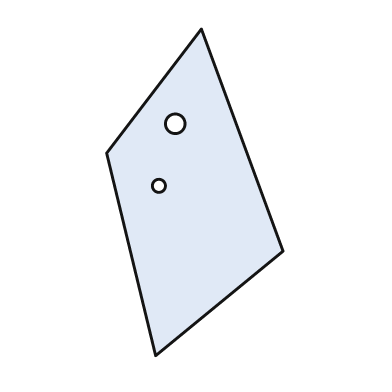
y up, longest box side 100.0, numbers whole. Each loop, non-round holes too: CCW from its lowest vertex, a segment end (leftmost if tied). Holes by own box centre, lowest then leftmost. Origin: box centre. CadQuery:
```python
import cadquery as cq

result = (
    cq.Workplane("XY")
    .moveTo(-12.0, -50.0)
    .lineTo(27.0, -18.0)
    .lineTo(2.0, 50.0)
    .lineTo(-27.0, 12.0)
    .close()
    .moveTo(-11.0, 2.0)
    .circle(2.0)
    .moveTo(-6.0, 21.0)
    .circle(3.0)
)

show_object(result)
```